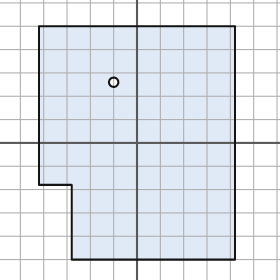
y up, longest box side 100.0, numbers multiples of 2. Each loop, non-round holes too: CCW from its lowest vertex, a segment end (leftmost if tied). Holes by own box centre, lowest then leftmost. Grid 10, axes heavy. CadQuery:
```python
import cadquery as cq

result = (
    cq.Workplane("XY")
    .moveTo(-28.0, -50.0)
    .lineTo(42.0, -50.0)
    .lineTo(42.0, 50.0)
    .lineTo(-42.0, 50.0)
    .lineTo(-42.0, -18.0)
    .lineTo(-28.0, -18.0)
    .close()
    .moveTo(-10.0, 26.0)
    .circle(2.0)
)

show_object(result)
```